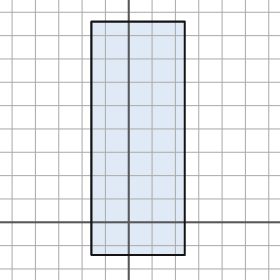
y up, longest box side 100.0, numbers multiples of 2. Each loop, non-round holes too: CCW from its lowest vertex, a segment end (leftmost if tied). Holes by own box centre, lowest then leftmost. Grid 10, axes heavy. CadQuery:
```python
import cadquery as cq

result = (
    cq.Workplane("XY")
    .moveTo(-16.0, -14.0)
    .lineTo(24.0, -14.0)
    .lineTo(24.0, 86.0)
    .lineTo(-16.0, 86.0)
    .close()
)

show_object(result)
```